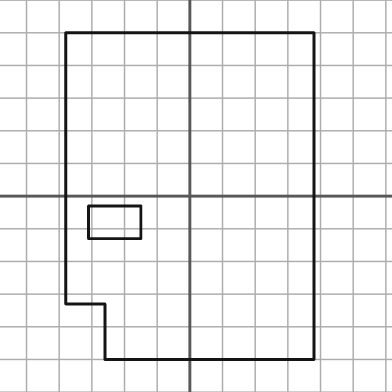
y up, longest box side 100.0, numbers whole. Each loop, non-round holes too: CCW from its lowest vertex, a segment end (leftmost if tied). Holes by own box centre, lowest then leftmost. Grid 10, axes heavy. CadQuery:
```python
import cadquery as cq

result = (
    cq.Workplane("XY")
    .moveTo(-26.0, -50.0)
    .lineTo(38.0, -50.0)
    .lineTo(38.0, 50.0)
    .lineTo(-38.0, 50.0)
    .lineTo(-38.0, -33.0)
    .lineTo(-26.0, -33.0)
    .close()
    .moveTo(-31.0, -13.0)
    .lineTo(-15.0, -13.0)
    .lineTo(-15.0, -3.0)
    .lineTo(-31.0, -3.0)
    .close()
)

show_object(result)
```